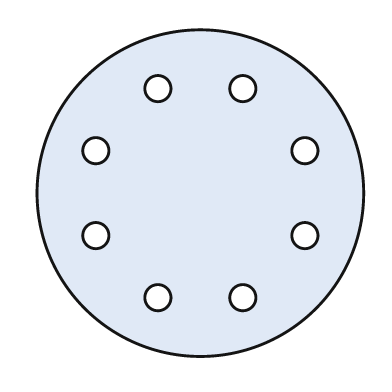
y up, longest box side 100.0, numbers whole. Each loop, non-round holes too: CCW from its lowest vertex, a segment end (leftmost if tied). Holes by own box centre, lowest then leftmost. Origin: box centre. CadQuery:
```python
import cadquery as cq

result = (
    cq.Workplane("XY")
    .moveTo(0.0, 0.0)
    .circle(50.0)
    .moveTo(-13.0, -32.0)
    .circle(4.0)
    .moveTo(13.0, -32.0)
    .circle(4.0)
    .moveTo(-32.0, -13.0)
    .circle(4.0)
    .moveTo(32.0, -13.0)
    .circle(4.0)
    .moveTo(-32.0, 13.0)
    .circle(4.0)
    .moveTo(32.0, 13.0)
    .circle(4.0)
    .moveTo(-13.0, 32.0)
    .circle(4.0)
    .moveTo(13.0, 32.0)
    .circle(4.0)
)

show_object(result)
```